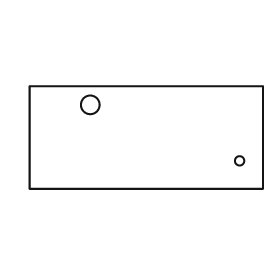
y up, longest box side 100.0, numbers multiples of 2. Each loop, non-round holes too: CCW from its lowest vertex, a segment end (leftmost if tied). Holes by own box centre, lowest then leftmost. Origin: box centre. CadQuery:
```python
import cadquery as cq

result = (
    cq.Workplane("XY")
    .moveTo(-50.0, -22.0)
    .lineTo(50.0, -22.0)
    .lineTo(50.0, 22.0)
    .lineTo(-50.0, 22.0)
    .close()
    .moveTo(40.0, -10.0)
    .circle(2.0)
    .moveTo(-24.0, 14.0)
    .circle(4.0)
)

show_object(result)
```